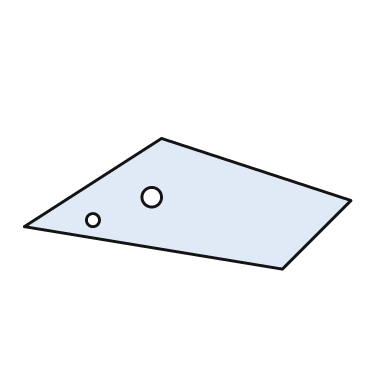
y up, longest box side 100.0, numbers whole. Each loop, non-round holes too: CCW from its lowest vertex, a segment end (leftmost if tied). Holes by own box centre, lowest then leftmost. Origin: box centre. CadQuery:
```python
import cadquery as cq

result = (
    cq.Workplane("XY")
    .moveTo(29.0, -20.0)
    .lineTo(50.0, 1.0)
    .lineTo(-8.0, 20.0)
    .lineTo(-50.0, -7.0)
    .close()
    .moveTo(-29.0, -5.0)
    .circle(2.0)
    .moveTo(-11.0, 2.0)
    .circle(3.0)
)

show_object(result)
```